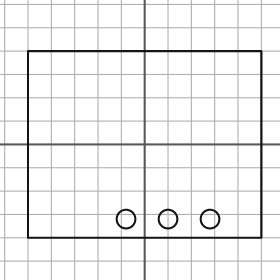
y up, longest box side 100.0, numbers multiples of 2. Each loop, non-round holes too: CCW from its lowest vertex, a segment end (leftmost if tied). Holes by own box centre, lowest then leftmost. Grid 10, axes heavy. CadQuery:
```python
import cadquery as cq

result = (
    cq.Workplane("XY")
    .moveTo(-50.0, -40.0)
    .lineTo(50.0, -40.0)
    .lineTo(50.0, 40.0)
    .lineTo(-50.0, 40.0)
    .close()
    .moveTo(-8.0, -32.0)
    .circle(4.0)
    .moveTo(10.0, -32.0)
    .circle(4.0)
    .moveTo(28.0, -32.0)
    .circle(4.0)
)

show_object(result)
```